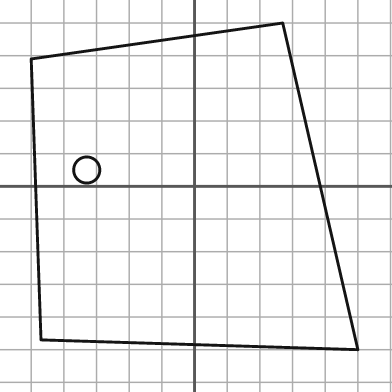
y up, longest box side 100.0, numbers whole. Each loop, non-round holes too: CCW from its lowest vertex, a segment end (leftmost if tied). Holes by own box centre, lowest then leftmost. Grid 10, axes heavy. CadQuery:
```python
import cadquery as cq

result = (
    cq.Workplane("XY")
    .moveTo(50.0, -50.0)
    .lineTo(27.0, 50.0)
    .lineTo(-50.0, 39.0)
    .lineTo(-47.0, -47.0)
    .close()
    .moveTo(-33.0, 5.0)
    .circle(4.0)
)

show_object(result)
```